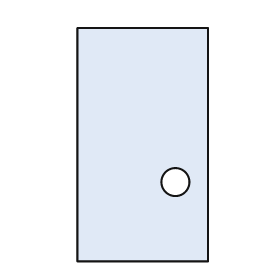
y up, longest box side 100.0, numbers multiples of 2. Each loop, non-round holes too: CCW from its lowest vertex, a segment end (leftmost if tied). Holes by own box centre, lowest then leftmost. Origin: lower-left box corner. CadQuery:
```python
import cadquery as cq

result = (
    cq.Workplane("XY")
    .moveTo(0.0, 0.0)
    .lineTo(56.0, 0.0)
    .lineTo(56.0, 100.0)
    .lineTo(0.0, 100.0)
    .close()
    .moveTo(42.0, 34.0)
    .circle(6.0)
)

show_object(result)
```